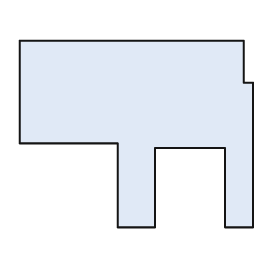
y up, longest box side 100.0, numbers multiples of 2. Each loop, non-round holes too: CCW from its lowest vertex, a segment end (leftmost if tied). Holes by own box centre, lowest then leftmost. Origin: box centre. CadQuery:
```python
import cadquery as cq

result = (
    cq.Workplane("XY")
    .moveTo(-8.0, -40.0)
    .lineTo(8.0, -40.0)
    .lineTo(8.0, -6.0)
    .lineTo(38.0, -6.0)
    .lineTo(38.0, -40.0)
    .lineTo(50.0, -40.0)
    .lineTo(50.0, 22.0)
    .lineTo(46.0, 22.0)
    .lineTo(46.0, 40.0)
    .lineTo(-50.0, 40.0)
    .lineTo(-50.0, -4.0)
    .lineTo(-8.0, -4.0)
    .close()
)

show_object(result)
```